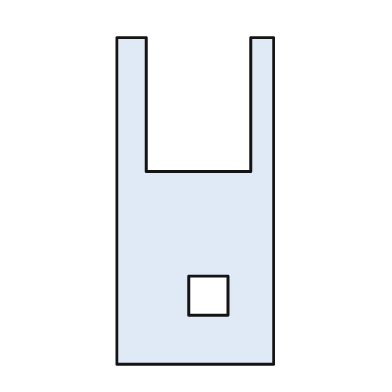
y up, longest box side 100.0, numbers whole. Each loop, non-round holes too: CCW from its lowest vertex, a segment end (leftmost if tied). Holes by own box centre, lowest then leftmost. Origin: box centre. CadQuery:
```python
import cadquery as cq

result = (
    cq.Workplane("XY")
    .moveTo(-24.0, -50.0)
    .lineTo(24.0, -50.0)
    .lineTo(24.0, 50.0)
    .lineTo(17.0, 50.0)
    .lineTo(17.0, 9.0)
    .lineTo(-15.0, 9.0)
    .lineTo(-15.0, 50.0)
    .lineTo(-24.0, 50.0)
    .close()
    .moveTo(-2.0, -35.0)
    .lineTo(10.0, -35.0)
    .lineTo(10.0, -23.0)
    .lineTo(-2.0, -23.0)
    .close()
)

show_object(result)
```